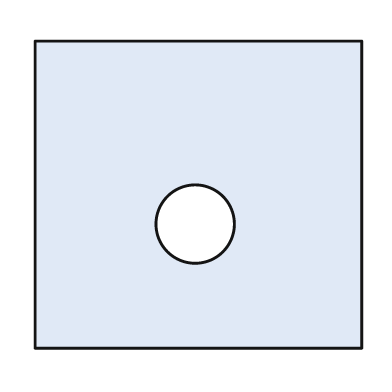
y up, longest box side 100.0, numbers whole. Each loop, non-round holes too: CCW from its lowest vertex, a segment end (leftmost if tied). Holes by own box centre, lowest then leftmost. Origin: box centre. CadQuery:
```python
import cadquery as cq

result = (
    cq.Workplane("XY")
    .moveTo(-50.0, -47.0)
    .lineTo(50.0, -47.0)
    .lineTo(50.0, 47.0)
    .lineTo(-50.0, 47.0)
    .close()
    .moveTo(-1.0, -9.0)
    .circle(12.0)
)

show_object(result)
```